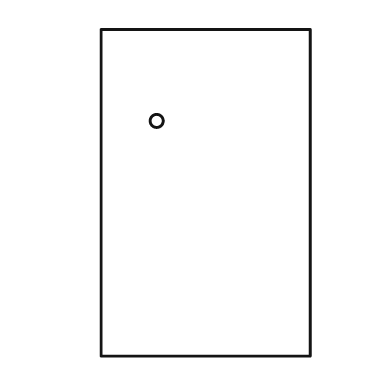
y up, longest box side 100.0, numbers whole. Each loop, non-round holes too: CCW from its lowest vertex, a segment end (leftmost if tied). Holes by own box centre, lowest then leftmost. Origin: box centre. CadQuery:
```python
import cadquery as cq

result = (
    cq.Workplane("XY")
    .moveTo(-32.0, -50.0)
    .lineTo(32.0, -50.0)
    .lineTo(32.0, 50.0)
    .lineTo(-32.0, 50.0)
    .close()
    .moveTo(-15.0, 22.0)
    .circle(2.0)
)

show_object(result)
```